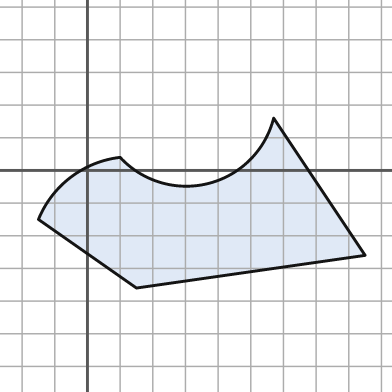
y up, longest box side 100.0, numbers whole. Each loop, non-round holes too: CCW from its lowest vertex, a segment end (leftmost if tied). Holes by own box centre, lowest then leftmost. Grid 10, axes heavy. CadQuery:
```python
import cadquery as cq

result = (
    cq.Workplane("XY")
    .moveTo(15.0, -36.0)
    .lineTo(85.0, -26.0)
    .lineTo(57.0, 16.0)
    .threePointArc((37.0, -4.0), (10.0, 4.0))
    .threePointArc((-5.0, -2.0), (-15.0, -15.0))
    .close()
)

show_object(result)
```